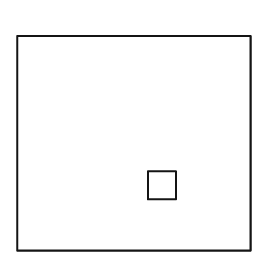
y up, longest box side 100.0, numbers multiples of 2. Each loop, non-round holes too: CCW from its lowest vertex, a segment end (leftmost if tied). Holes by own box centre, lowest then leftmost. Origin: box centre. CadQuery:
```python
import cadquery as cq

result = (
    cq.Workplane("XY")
    .moveTo(-50.0, -46.0)
    .lineTo(50.0, -46.0)
    .lineTo(50.0, 46.0)
    .lineTo(-50.0, 46.0)
    .close()
    .moveTo(6.0, -24.0)
    .lineTo(18.0, -24.0)
    .lineTo(18.0, -12.0)
    .lineTo(6.0, -12.0)
    .close()
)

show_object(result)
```